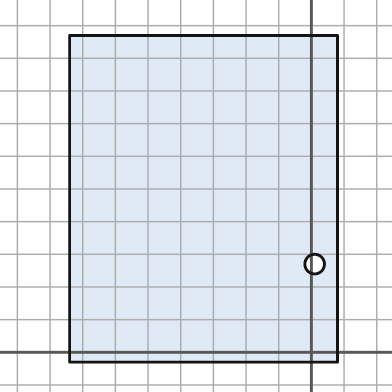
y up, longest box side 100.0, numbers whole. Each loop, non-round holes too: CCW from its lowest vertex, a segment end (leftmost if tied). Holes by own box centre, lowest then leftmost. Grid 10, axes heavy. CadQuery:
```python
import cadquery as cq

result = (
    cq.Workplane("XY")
    .moveTo(-74.0, -3.0)
    .lineTo(8.0, -3.0)
    .lineTo(8.0, 97.0)
    .lineTo(-74.0, 97.0)
    .close()
    .moveTo(1.0, 27.0)
    .circle(3.0)
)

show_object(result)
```